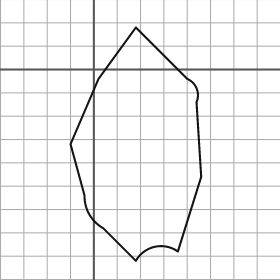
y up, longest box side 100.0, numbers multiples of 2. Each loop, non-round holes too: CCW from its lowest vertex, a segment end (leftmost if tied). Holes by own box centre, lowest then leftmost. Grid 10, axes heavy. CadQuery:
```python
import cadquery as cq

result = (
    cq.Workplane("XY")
    .moveTo(18.0, -82.0)
    .threePointArc((26.0, -76.0), (36.0, -78.0))
    .lineTo(46.0, -46.0)
    .lineTo(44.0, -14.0)
    .threePointArc((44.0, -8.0), (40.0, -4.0))
    .lineTo(18.0, 18.0)
    .lineTo(2.0, -4.0)
    .lineTo(-10.0, -32.0)
    .lineTo(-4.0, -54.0)
    .threePointArc((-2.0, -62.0), (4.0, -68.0))
    .close()
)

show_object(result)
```